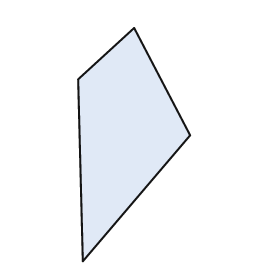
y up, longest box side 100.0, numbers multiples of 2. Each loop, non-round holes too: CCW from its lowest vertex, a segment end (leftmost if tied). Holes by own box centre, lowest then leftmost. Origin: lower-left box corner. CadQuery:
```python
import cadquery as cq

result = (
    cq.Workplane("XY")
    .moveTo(2.0, 0.0)
    .lineTo(48.0, 54.0)
    .lineTo(24.0, 100.0)
    .lineTo(0.0, 78.0)
    .close()
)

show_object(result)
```